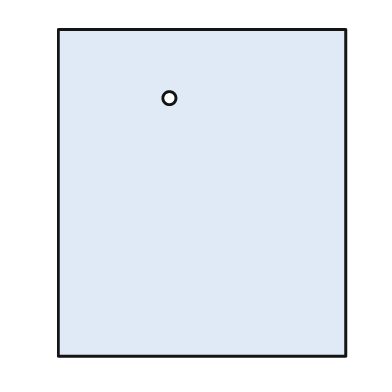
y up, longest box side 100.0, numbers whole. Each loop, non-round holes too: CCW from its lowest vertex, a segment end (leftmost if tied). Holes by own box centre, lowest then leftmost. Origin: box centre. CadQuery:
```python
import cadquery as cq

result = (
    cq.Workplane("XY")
    .moveTo(-44.0, -50.0)
    .lineTo(44.0, -50.0)
    .lineTo(44.0, 50.0)
    .lineTo(-44.0, 50.0)
    .close()
    .moveTo(-10.0, 29.0)
    .circle(2.0)
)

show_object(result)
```